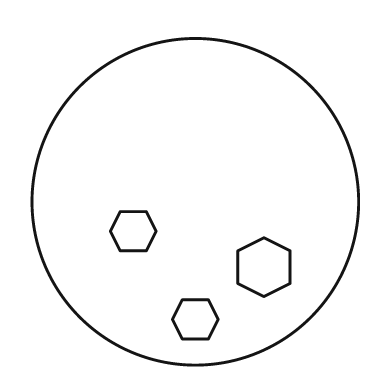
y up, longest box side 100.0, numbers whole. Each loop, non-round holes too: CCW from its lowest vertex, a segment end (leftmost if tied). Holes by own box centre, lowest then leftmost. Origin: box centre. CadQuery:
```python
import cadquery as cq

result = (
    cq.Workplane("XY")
    .moveTo(0.0, 0.0)
    .circle(50.0)
    .moveTo(-4.0, -42.0)
    .lineTo(4.0, -42.0)
    .lineTo(7.0, -36.0)
    .lineTo(4.0, -30.0)
    .lineTo(-4.0, -30.0)
    .lineTo(-7.0, -36.0)
    .close()
    .moveTo(21.0, -29.0)
    .lineTo(29.0, -25.0)
    .lineTo(29.0, -15.0)
    .lineTo(21.0, -11.0)
    .lineTo(13.0, -15.0)
    .lineTo(13.0, -25.0)
    .close()
    .moveTo(-23.0, -15.0)
    .lineTo(-15.0, -15.0)
    .lineTo(-12.0, -9.0)
    .lineTo(-15.0, -3.0)
    .lineTo(-23.0, -3.0)
    .lineTo(-26.0, -9.0)
    .close()
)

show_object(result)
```